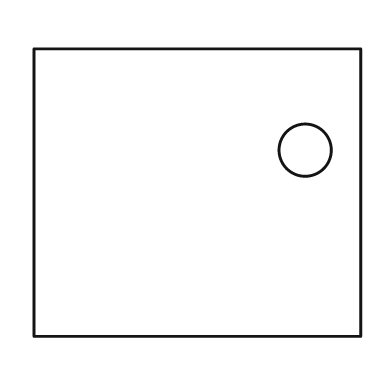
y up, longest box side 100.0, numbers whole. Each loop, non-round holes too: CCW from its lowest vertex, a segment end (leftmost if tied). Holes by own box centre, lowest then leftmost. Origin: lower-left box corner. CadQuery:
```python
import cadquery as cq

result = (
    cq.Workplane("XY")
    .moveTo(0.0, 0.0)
    .lineTo(100.0, 0.0)
    .lineTo(100.0, 88.0)
    .lineTo(0.0, 88.0)
    .close()
    .moveTo(83.0, 57.0)
    .circle(8.0)
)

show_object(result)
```